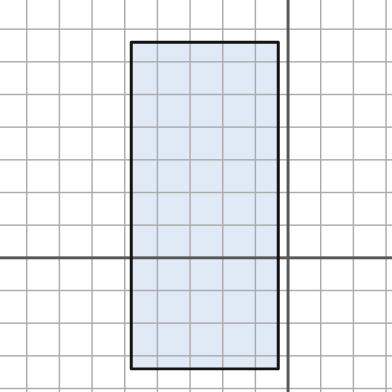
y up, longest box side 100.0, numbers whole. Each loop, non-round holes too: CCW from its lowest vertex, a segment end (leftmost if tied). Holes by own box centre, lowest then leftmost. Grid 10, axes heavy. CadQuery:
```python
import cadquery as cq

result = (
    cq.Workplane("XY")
    .moveTo(-48.0, -34.0)
    .lineTo(-3.0, -34.0)
    .lineTo(-3.0, 66.0)
    .lineTo(-48.0, 66.0)
    .close()
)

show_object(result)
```